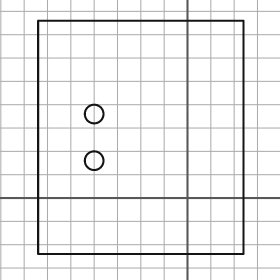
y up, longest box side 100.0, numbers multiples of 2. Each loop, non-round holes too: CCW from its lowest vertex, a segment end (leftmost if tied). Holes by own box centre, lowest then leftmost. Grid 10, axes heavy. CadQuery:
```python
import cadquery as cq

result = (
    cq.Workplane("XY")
    .moveTo(-64.0, -24.0)
    .lineTo(24.0, -24.0)
    .lineTo(24.0, 76.0)
    .lineTo(-64.0, 76.0)
    .close()
    .moveTo(-40.0, 16.0)
    .circle(4.0)
    .moveTo(-40.0, 36.0)
    .circle(4.0)
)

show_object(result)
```